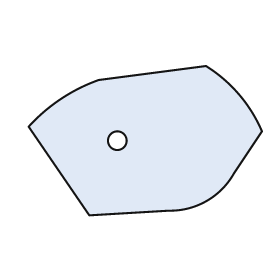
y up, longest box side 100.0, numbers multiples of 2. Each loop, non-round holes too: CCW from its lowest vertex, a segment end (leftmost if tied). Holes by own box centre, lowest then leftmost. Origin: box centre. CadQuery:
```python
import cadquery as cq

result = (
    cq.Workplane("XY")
    .moveTo(-24.0, -32.0)
    .lineTo(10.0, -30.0)
    .threePointArc((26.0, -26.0), (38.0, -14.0))
    .lineTo(50.0, 4.0)
    .threePointArc((40.0, 20.0), (26.0, 32.0))
    .lineTo(-20.0, 26.0)
    .threePointArc((-36.0, 18.0), (-50.0, 6.0))
    .close()
    .moveTo(-12.0, 0.0)
    .circle(4.0)
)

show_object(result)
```